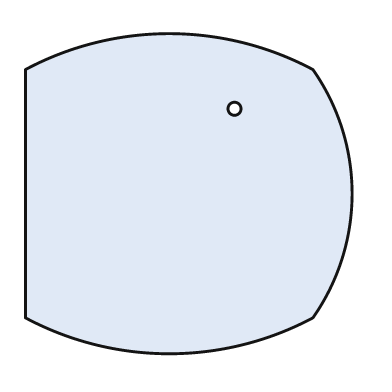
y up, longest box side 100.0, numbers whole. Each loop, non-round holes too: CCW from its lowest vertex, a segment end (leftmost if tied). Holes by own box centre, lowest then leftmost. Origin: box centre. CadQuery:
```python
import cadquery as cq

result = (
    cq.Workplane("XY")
    .moveTo(-50.0, -38.0)
    .threePointArc((-6.0, -49.0), (38.0, -38.0))
    .threePointArc((50.0, 0.0), (38.0, 38.0))
    .threePointArc((-6.0, 49.0), (-50.0, 38.0))
    .close()
    .moveTo(14.0, 26.0)
    .circle(2.0)
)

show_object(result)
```